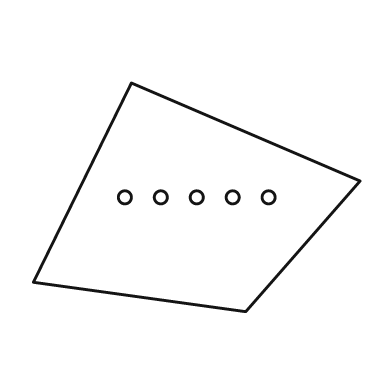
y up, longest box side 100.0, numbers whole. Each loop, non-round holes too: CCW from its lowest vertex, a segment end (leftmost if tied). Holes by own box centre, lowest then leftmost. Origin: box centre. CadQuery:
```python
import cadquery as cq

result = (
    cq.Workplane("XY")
    .moveTo(15.0, -35.0)
    .lineTo(50.0, 5.0)
    .lineTo(-20.0, 35.0)
    .lineTo(-50.0, -26.0)
    .close()
    .moveTo(-22.0, 0.0)
    .circle(2.0)
    .moveTo(-11.0, 0.0)
    .circle(2.0)
    .moveTo(0.0, 0.0)
    .circle(2.0)
    .moveTo(11.0, 0.0)
    .circle(2.0)
    .moveTo(22.0, 0.0)
    .circle(2.0)
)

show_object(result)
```